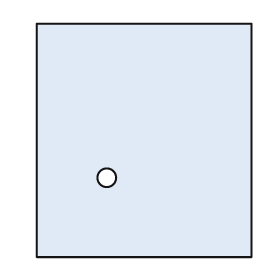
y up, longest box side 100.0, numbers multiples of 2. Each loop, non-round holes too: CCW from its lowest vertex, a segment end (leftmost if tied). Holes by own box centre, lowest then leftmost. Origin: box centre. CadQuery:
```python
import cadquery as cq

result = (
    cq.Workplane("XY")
    .moveTo(-46.0, -50.0)
    .lineTo(46.0, -50.0)
    .lineTo(46.0, 50.0)
    .lineTo(-46.0, 50.0)
    .close()
    .moveTo(-16.0, -16.0)
    .circle(4.0)
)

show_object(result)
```